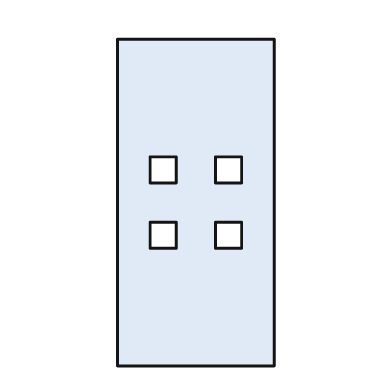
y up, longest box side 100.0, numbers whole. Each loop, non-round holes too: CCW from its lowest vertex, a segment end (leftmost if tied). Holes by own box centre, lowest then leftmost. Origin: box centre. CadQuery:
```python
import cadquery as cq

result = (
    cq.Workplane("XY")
    .moveTo(-24.0, -50.0)
    .lineTo(24.0, -50.0)
    .lineTo(24.0, 50.0)
    .lineTo(-24.0, 50.0)
    .close()
    .moveTo(-14.0, -14.0)
    .lineTo(-6.0, -14.0)
    .lineTo(-6.0, -6.0)
    .lineTo(-14.0, -6.0)
    .close()
    .moveTo(6.0, -14.0)
    .lineTo(14.0, -14.0)
    .lineTo(14.0, -6.0)
    .lineTo(6.0, -6.0)
    .close()
    .moveTo(-14.0, 6.0)
    .lineTo(-6.0, 6.0)
    .lineTo(-6.0, 14.0)
    .lineTo(-14.0, 14.0)
    .close()
    .moveTo(6.0, 6.0)
    .lineTo(14.0, 6.0)
    .lineTo(14.0, 14.0)
    .lineTo(6.0, 14.0)
    .close()
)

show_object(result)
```